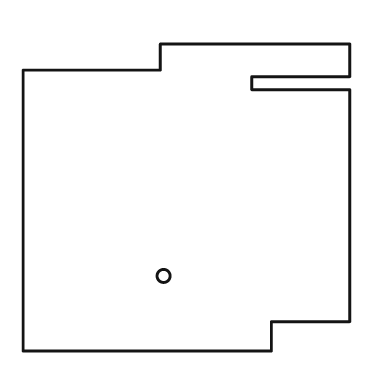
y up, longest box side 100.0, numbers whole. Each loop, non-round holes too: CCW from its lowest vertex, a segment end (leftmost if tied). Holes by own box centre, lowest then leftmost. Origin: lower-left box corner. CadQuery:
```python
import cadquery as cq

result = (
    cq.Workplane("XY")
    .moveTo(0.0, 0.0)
    .lineTo(76.0, 0.0)
    .lineTo(76.0, 9.0)
    .lineTo(100.0, 9.0)
    .lineTo(100.0, 80.0)
    .lineTo(70.0, 80.0)
    .lineTo(70.0, 84.0)
    .lineTo(100.0, 84.0)
    .lineTo(100.0, 94.0)
    .lineTo(42.0, 94.0)
    .lineTo(42.0, 86.0)
    .lineTo(0.0, 86.0)
    .close()
    .moveTo(43.0, 23.0)
    .circle(2.0)
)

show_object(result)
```